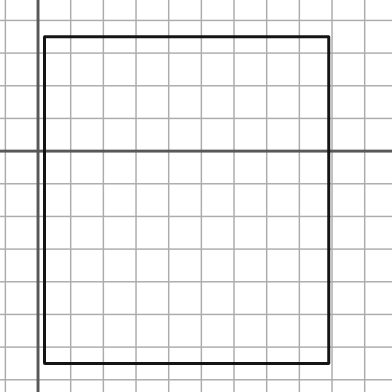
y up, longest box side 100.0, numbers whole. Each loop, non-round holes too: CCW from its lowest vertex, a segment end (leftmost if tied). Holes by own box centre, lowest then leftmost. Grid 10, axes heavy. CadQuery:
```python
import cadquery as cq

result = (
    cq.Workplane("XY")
    .moveTo(2.0, -65.0)
    .lineTo(89.0, -65.0)
    .lineTo(89.0, 35.0)
    .lineTo(2.0, 35.0)
    .close()
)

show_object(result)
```